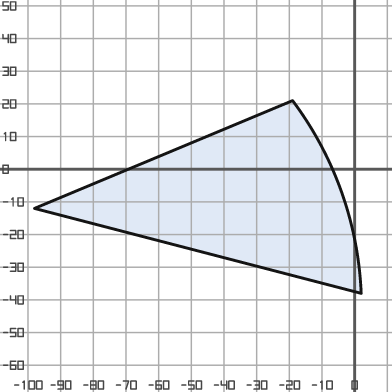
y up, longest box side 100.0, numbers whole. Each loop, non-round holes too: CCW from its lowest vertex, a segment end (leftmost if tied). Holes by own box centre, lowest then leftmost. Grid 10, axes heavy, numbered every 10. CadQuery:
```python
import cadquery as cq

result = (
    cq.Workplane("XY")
    .moveTo(2.0, -38.0)
    .threePointArc((-4.0, -7.0), (-19.0, 21.0))
    .lineTo(-98.0, -12.0)
    .close()
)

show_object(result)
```